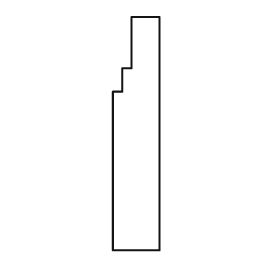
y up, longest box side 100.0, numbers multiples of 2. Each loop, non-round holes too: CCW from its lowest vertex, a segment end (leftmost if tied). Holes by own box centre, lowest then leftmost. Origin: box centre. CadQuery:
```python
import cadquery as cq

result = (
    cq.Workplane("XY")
    .moveTo(-10.0, -50.0)
    .lineTo(10.0, -50.0)
    .lineTo(10.0, 50.0)
    .lineTo(-2.0, 50.0)
    .lineTo(-2.0, 28.0)
    .lineTo(-6.0, 28.0)
    .lineTo(-6.0, 18.0)
    .lineTo(-10.0, 18.0)
    .close()
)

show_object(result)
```